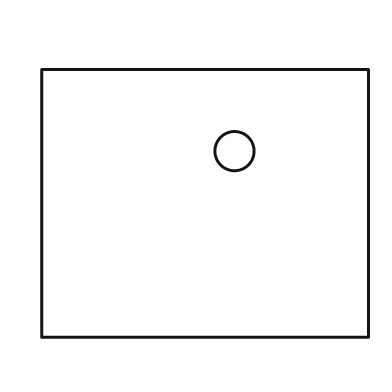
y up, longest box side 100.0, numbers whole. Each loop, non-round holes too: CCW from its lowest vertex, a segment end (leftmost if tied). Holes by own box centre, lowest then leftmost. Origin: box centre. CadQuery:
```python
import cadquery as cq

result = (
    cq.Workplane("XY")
    .moveTo(-50.0, -41.0)
    .lineTo(50.0, -41.0)
    .lineTo(50.0, 41.0)
    .lineTo(-50.0, 41.0)
    .close()
    .moveTo(9.0, 16.0)
    .circle(6.0)
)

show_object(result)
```